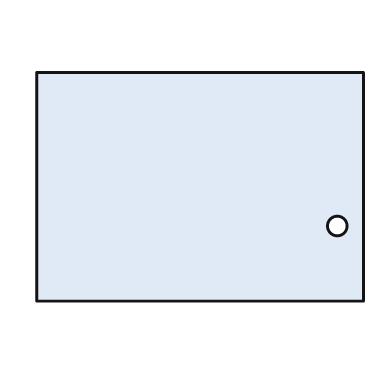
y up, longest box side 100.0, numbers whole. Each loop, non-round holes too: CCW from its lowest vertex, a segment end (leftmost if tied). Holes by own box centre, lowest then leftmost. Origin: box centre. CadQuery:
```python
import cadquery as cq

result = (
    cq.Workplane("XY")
    .moveTo(-50.0, -35.0)
    .lineTo(50.0, -35.0)
    .lineTo(50.0, 35.0)
    .lineTo(-50.0, 35.0)
    .close()
    .moveTo(42.0, -12.0)
    .circle(3.0)
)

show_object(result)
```